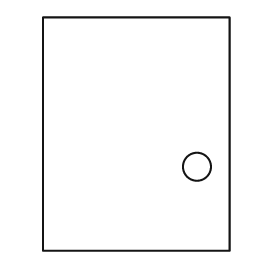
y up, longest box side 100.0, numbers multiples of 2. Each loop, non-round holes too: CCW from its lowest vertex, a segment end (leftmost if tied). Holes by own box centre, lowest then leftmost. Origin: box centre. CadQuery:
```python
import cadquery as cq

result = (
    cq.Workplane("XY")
    .moveTo(-40.0, -50.0)
    .lineTo(40.0, -50.0)
    .lineTo(40.0, 50.0)
    .lineTo(-40.0, 50.0)
    .close()
    .moveTo(26.0, -14.0)
    .circle(6.0)
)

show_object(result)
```